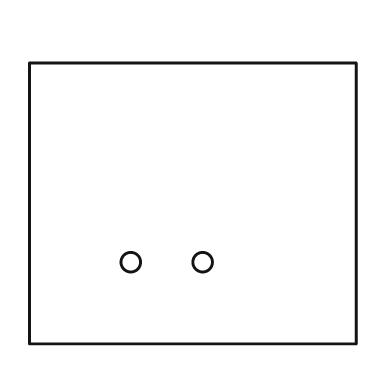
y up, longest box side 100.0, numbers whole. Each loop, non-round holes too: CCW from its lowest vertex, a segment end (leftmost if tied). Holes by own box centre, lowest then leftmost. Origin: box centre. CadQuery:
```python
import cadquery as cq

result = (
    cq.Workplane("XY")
    .moveTo(-50.0, -43.0)
    .lineTo(50.0, -43.0)
    .lineTo(50.0, 43.0)
    .lineTo(-50.0, 43.0)
    .close()
    .moveTo(-19.0, -18.0)
    .circle(3.0)
    .moveTo(3.0, -18.0)
    .circle(3.0)
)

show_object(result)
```